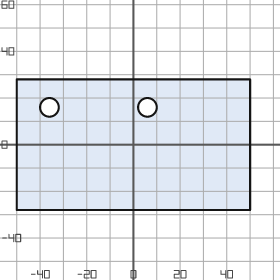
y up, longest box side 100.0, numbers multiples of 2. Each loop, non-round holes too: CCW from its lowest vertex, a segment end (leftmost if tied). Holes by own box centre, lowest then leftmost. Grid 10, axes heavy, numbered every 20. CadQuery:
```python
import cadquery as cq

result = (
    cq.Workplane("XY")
    .moveTo(-50.0, -28.0)
    .lineTo(50.0, -28.0)
    .lineTo(50.0, 28.0)
    .lineTo(-50.0, 28.0)
    .close()
    .moveTo(-36.0, 16.0)
    .circle(4.0)
    .moveTo(6.0, 16.0)
    .circle(4.0)
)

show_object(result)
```